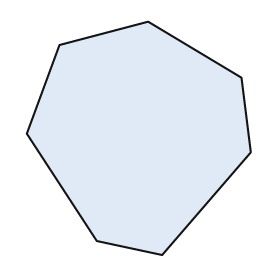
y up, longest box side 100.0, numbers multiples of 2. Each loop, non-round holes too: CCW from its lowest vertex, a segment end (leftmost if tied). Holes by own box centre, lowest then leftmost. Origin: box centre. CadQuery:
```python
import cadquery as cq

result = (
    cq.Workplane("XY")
    .moveTo(10.0, -50.0)
    .lineTo(48.0, -6.0)
    .lineTo(44.0, 26.0)
    .lineTo(4.0, 50.0)
    .lineTo(-34.0, 40.0)
    .lineTo(-48.0, 2.0)
    .lineTo(-18.0, -44.0)
    .close()
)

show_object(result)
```